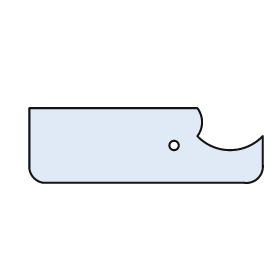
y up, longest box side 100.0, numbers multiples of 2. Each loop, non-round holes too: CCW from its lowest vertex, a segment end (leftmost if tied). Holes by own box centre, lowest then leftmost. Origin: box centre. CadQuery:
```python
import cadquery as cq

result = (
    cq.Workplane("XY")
    .moveTo(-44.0, -16.0)
    .lineTo(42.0, -16.0)
    .threePointArc((48.0, -14.0), (50.0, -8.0))
    .lineTo(50.0, 4.0)
    .threePointArc((36.0, -2.0), (22.0, 4.0))
    .threePointArc((24.0, 10.0), (22.0, 16.0))
    .lineTo(-50.0, 16.0)
    .lineTo(-50.0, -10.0)
    .threePointArc((-48.0, -14.0), (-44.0, -16.0))
    .close()
    .moveTo(12.0, 0.0)
    .circle(2.0)
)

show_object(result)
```